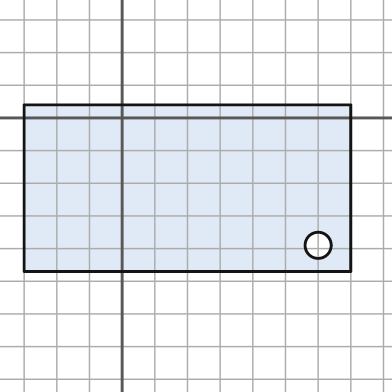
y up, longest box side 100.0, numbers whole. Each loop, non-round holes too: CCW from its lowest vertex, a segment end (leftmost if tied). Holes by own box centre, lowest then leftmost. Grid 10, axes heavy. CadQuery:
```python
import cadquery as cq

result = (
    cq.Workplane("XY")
    .moveTo(-30.0, -47.0)
    .lineTo(70.0, -47.0)
    .lineTo(70.0, 4.0)
    .lineTo(-30.0, 4.0)
    .close()
    .moveTo(60.0, -39.0)
    .circle(4.0)
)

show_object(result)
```